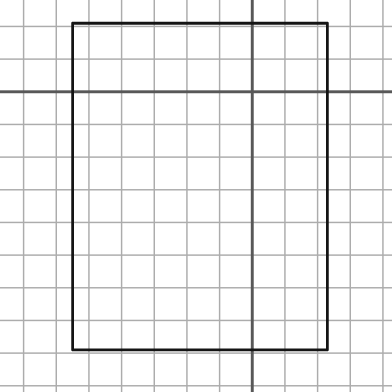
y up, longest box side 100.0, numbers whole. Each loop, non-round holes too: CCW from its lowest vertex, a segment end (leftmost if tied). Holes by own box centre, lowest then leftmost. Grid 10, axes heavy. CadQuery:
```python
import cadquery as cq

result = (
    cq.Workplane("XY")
    .moveTo(-55.0, -79.0)
    .lineTo(23.0, -79.0)
    .lineTo(23.0, 21.0)
    .lineTo(-55.0, 21.0)
    .close()
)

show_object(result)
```